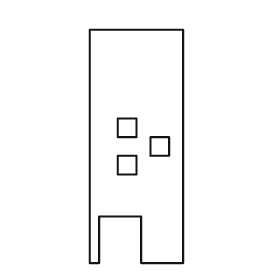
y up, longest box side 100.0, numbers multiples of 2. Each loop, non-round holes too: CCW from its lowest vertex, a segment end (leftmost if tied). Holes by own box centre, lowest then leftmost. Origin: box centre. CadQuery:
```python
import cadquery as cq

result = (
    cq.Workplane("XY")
    .moveTo(-20.0, -50.0)
    .lineTo(-16.0, -50.0)
    .lineTo(-16.0, -30.0)
    .lineTo(2.0, -30.0)
    .lineTo(2.0, -50.0)
    .lineTo(20.0, -50.0)
    .lineTo(20.0, 50.0)
    .lineTo(-20.0, 50.0)
    .close()
    .moveTo(-8.0, -12.0)
    .lineTo(0.0, -12.0)
    .lineTo(0.0, -4.0)
    .lineTo(-8.0, -4.0)
    .close()
    .moveTo(6.0, -4.0)
    .lineTo(14.0, -4.0)
    .lineTo(14.0, 4.0)
    .lineTo(6.0, 4.0)
    .close()
    .moveTo(-8.0, 4.0)
    .lineTo(0.0, 4.0)
    .lineTo(0.0, 12.0)
    .lineTo(-8.0, 12.0)
    .close()
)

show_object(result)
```